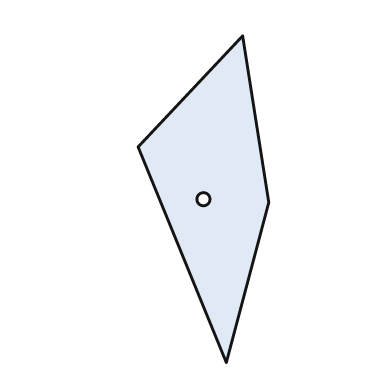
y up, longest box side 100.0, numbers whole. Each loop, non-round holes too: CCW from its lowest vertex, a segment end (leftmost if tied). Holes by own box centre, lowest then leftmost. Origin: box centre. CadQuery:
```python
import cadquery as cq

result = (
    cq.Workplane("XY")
    .moveTo(7.0, -50.0)
    .lineTo(20.0, -1.0)
    .lineTo(12.0, 50.0)
    .lineTo(-20.0, 16.0)
    .close()
    .moveTo(0.0, 0.0)
    .circle(2.0)
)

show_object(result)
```